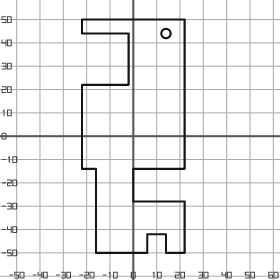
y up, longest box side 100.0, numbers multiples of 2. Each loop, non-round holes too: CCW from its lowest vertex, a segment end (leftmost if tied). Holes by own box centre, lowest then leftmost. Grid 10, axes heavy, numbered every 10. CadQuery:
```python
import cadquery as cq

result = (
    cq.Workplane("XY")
    .moveTo(-16.0, -50.0)
    .lineTo(6.0, -50.0)
    .lineTo(6.0, -42.0)
    .lineTo(14.0, -42.0)
    .lineTo(14.0, -50.0)
    .lineTo(22.0, -50.0)
    .lineTo(22.0, -28.0)
    .lineTo(0.0, -28.0)
    .lineTo(0.0, -14.0)
    .lineTo(22.0, -14.0)
    .lineTo(22.0, 50.0)
    .lineTo(-22.0, 50.0)
    .lineTo(-22.0, 44.0)
    .lineTo(-2.0, 44.0)
    .lineTo(-2.0, 22.0)
    .lineTo(-22.0, 22.0)
    .lineTo(-22.0, -14.0)
    .lineTo(-16.0, -14.0)
    .close()
    .moveTo(14.0, 44.0)
    .circle(2.0)
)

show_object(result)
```